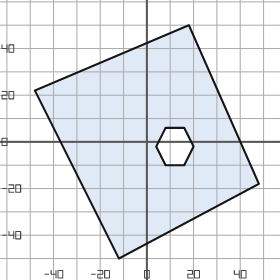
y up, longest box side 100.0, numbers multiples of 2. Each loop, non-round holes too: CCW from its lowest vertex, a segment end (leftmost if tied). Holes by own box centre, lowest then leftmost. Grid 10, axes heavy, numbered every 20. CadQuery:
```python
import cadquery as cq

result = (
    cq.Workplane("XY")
    .moveTo(-12.0, -50.0)
    .lineTo(48.0, -18.0)
    .lineTo(18.0, 50.0)
    .lineTo(-48.0, 22.0)
    .close()
    .moveTo(8.0, -10.0)
    .lineTo(16.0, -10.0)
    .lineTo(20.0, -2.0)
    .lineTo(16.0, 6.0)
    .lineTo(8.0, 6.0)
    .lineTo(4.0, -2.0)
    .close()
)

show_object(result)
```